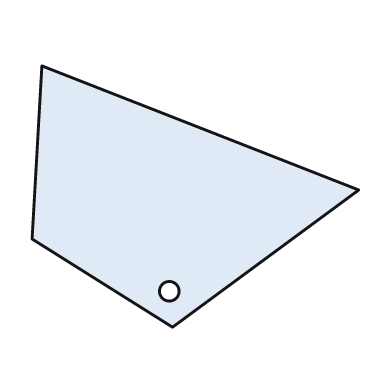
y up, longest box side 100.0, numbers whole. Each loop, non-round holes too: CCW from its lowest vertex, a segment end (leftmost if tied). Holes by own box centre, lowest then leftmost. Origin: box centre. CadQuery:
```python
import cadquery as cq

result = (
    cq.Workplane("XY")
    .moveTo(-7.0, -40.0)
    .lineTo(50.0, 2.0)
    .lineTo(-47.0, 40.0)
    .lineTo(-50.0, -13.0)
    .close()
    .moveTo(-8.0, -29.0)
    .circle(3.0)
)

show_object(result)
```